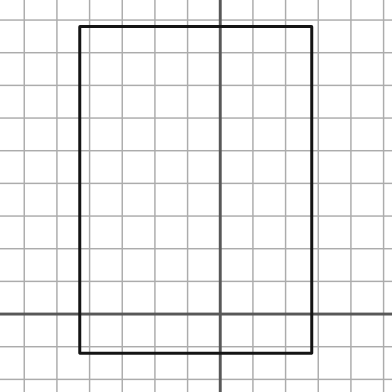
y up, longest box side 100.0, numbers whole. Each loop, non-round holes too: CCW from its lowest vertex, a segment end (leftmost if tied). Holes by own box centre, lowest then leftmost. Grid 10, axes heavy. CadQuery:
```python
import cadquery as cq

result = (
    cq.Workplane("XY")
    .moveTo(-43.0, -12.0)
    .lineTo(28.0, -12.0)
    .lineTo(28.0, 88.0)
    .lineTo(-43.0, 88.0)
    .close()
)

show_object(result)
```